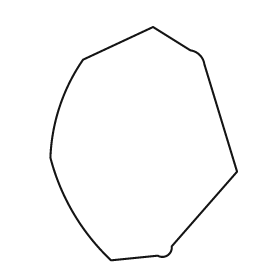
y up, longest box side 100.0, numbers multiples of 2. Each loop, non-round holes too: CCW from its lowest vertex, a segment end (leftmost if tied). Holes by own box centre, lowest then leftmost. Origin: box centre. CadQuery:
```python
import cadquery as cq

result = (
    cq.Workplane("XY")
    .moveTo(-14.0, -50.0)
    .lineTo(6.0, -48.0)
    .threePointArc((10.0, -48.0), (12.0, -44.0))
    .lineTo(40.0, -12.0)
    .lineTo(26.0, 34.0)
    .threePointArc((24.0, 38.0), (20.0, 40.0))
    .lineTo(4.0, 50.0)
    .lineTo(-26.0, 36.0)
    .threePointArc((-36.0, 16.0), (-40.0, -6.0))
    .threePointArc((-30.0, -30.0), (-14.0, -50.0))
    .close()
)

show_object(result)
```